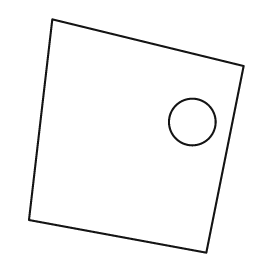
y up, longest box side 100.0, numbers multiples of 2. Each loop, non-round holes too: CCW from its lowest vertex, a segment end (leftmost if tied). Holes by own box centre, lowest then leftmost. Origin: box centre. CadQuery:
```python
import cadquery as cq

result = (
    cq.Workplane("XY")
    .moveTo(30.0, -50.0)
    .lineTo(46.0, 30.0)
    .lineTo(-36.0, 50.0)
    .lineTo(-46.0, -36.0)
    .close()
    .moveTo(24.0, 6.0)
    .circle(10.0)
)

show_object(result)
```